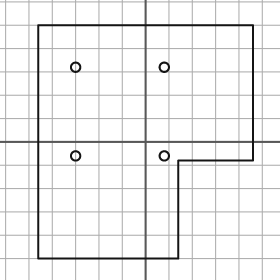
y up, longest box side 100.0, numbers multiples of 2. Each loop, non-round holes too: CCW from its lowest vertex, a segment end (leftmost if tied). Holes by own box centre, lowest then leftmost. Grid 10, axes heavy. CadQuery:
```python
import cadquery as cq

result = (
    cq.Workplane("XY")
    .moveTo(-46.0, -50.0)
    .lineTo(14.0, -50.0)
    .lineTo(14.0, -8.0)
    .lineTo(46.0, -8.0)
    .lineTo(46.0, 50.0)
    .lineTo(-46.0, 50.0)
    .close()
    .moveTo(-30.0, -6.0)
    .circle(2.0)
    .moveTo(8.0, -6.0)
    .circle(2.0)
    .moveTo(-30.0, 32.0)
    .circle(2.0)
    .moveTo(8.0, 32.0)
    .circle(2.0)
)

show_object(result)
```